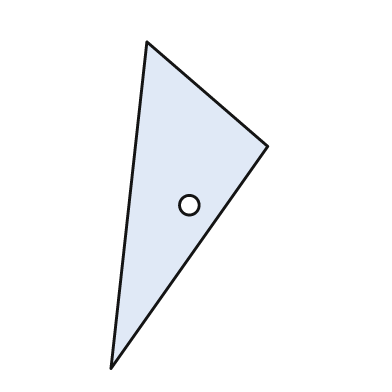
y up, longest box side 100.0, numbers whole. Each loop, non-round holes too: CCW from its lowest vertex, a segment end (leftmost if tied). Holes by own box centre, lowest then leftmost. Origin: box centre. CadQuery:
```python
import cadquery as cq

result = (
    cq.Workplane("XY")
    .moveTo(-24.0, -50.0)
    .lineTo(24.0, 18.0)
    .lineTo(-13.0, 50.0)
    .close()
    .moveTo(0.0, 0.0)
    .circle(3.0)
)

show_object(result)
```